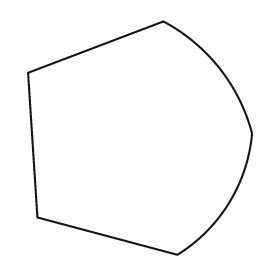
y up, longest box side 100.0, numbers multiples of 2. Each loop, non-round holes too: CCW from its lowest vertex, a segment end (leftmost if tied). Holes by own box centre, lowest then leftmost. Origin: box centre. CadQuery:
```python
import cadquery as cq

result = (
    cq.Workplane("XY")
    .moveTo(16.0, -50.0)
    .threePointArc((38.0, -28.0), (48.0, 2.0))
    .threePointArc((34.0, 30.0), (10.0, 50.0))
    .lineTo(-48.0, 28.0)
    .lineTo(-44.0, -34.0)
    .close()
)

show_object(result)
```